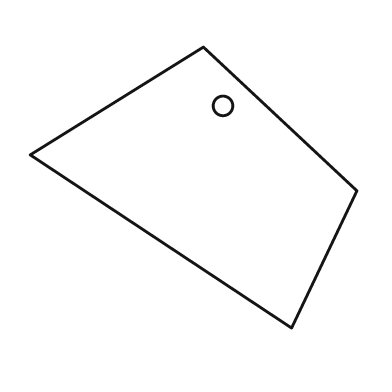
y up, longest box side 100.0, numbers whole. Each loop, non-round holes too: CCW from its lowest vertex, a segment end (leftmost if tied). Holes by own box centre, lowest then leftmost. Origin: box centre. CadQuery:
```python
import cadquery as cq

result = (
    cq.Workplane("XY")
    .moveTo(30.0, -43.0)
    .lineTo(50.0, -1.0)
    .lineTo(3.0, 43.0)
    .lineTo(-50.0, 10.0)
    .close()
    .moveTo(9.0, 25.0)
    .circle(3.0)
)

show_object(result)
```